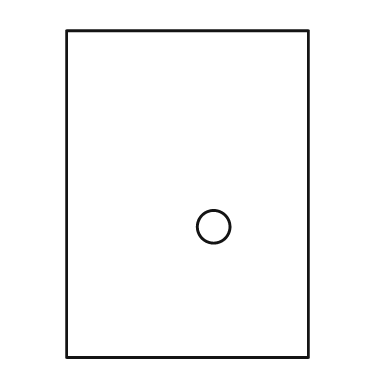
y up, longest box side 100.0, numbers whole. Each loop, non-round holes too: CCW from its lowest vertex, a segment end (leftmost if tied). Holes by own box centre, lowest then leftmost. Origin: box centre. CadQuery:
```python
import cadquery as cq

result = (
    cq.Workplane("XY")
    .moveTo(-37.0, -50.0)
    .lineTo(37.0, -50.0)
    .lineTo(37.0, 50.0)
    .lineTo(-37.0, 50.0)
    .close()
    .moveTo(8.0, -10.0)
    .circle(5.0)
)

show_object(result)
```